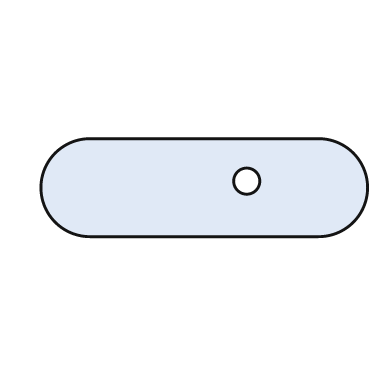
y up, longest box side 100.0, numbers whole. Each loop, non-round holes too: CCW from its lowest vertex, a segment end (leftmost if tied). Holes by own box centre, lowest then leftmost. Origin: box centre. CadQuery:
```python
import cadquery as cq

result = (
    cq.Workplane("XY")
    .moveTo(-35.0, -15.0)
    .lineTo(35.0, -15.0)
    .threePointArc((50.0, 0.0), (35.0, 15.0))
    .lineTo(-35.0, 15.0)
    .threePointArc((-50.0, 0.0), (-35.0, -15.0))
    .close()
    .moveTo(13.0, 2.0)
    .circle(4.0)
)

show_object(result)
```